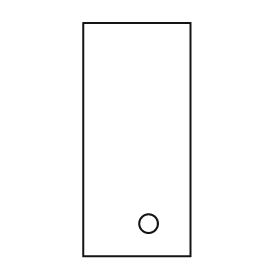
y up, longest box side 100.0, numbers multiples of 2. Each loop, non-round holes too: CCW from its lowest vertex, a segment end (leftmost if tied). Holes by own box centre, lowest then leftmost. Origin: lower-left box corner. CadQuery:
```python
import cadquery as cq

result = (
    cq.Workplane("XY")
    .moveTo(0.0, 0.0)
    .lineTo(46.0, 0.0)
    .lineTo(46.0, 100.0)
    .lineTo(0.0, 100.0)
    .close()
    .moveTo(28.0, 14.0)
    .circle(4.0)
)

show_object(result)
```